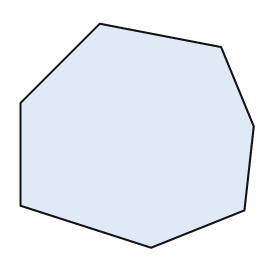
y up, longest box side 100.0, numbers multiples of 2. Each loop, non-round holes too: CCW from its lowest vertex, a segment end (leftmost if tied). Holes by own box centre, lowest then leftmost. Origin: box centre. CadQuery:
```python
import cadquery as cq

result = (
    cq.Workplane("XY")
    .moveTo(6.0, -48.0)
    .lineTo(46.0, -32.0)
    .lineTo(50.0, 4.0)
    .lineTo(36.0, 38.0)
    .lineTo(-16.0, 48.0)
    .lineTo(-50.0, 14.0)
    .lineTo(-50.0, -30.0)
    .close()
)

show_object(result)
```